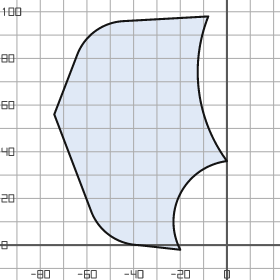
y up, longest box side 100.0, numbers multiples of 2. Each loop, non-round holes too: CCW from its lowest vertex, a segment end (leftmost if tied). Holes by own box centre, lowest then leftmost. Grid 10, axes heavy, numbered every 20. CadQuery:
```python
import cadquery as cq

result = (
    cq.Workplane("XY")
    .moveTo(-20.0, -2.0)
    .threePointArc((-20.0, 22.0), (0.0, 36.0))
    .threePointArc((-12.0, 66.0), (-8.0, 98.0))
    .lineTo(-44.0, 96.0)
    .threePointArc((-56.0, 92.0), (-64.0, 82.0))
    .lineTo(-74.0, 56.0)
    .lineTo(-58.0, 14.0)
    .threePointArc((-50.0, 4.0), (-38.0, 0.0))
    .close()
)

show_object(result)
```